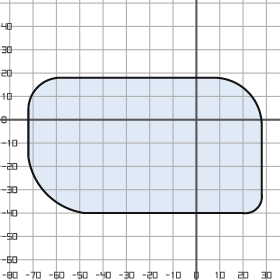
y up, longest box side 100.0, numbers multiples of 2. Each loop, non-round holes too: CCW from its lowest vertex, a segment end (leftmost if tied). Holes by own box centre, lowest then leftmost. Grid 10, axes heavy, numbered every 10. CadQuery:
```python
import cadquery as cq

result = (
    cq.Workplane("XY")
    .moveTo(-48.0, -40.0)
    .lineTo(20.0, -40.0)
    .threePointArc((26.0, -38.0), (28.0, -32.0))
    .lineTo(28.0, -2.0)
    .threePointArc((22.0, 12.0), (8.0, 18.0))
    .lineTo(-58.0, 18.0)
    .threePointArc((-68.0, 14.0), (-72.0, 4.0))
    .lineTo(-72.0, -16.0)
    .threePointArc((-64.0, -32.0), (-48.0, -40.0))
    .close()
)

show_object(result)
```